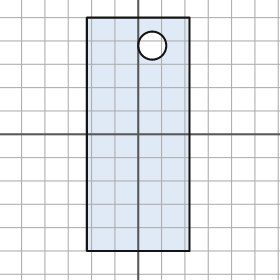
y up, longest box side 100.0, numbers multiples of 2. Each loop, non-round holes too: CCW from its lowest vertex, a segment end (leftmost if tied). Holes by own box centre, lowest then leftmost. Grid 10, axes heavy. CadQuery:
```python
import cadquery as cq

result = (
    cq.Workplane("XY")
    .moveTo(-22.0, -50.0)
    .lineTo(22.0, -50.0)
    .lineTo(22.0, 50.0)
    .lineTo(-22.0, 50.0)
    .close()
    .moveTo(6.0, 38.0)
    .circle(6.0)
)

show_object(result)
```